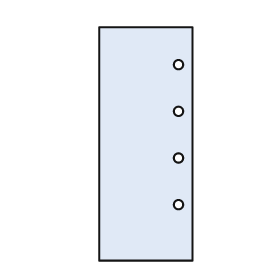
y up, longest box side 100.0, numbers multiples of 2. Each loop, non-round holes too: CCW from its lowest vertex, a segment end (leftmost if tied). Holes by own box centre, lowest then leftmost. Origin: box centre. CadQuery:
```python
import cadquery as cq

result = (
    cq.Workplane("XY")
    .moveTo(-20.0, -50.0)
    .lineTo(20.0, -50.0)
    .lineTo(20.0, 50.0)
    .lineTo(-20.0, 50.0)
    .close()
    .moveTo(14.0, -26.0)
    .circle(2.0)
    .moveTo(14.0, -6.0)
    .circle(2.0)
    .moveTo(14.0, 14.0)
    .circle(2.0)
    .moveTo(14.0, 34.0)
    .circle(2.0)
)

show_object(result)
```